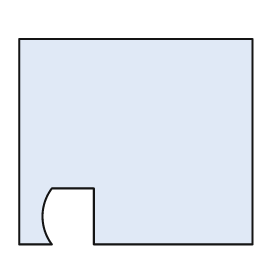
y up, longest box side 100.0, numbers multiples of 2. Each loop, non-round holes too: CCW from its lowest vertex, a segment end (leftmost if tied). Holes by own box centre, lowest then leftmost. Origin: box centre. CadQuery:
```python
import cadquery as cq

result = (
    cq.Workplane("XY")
    .moveTo(-50.0, -44.0)
    .lineTo(-36.0, -44.0)
    .threePointArc((-40.0, -32.0), (-36.0, -20.0))
    .lineTo(-18.0, -20.0)
    .lineTo(-18.0, -44.0)
    .lineTo(50.0, -44.0)
    .lineTo(50.0, 44.0)
    .lineTo(-50.0, 44.0)
    .close()
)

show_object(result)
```